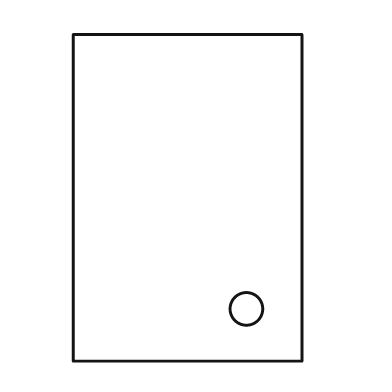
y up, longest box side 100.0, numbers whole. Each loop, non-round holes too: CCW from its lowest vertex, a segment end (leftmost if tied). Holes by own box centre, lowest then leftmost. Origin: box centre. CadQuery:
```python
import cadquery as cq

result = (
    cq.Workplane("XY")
    .moveTo(-35.0, -50.0)
    .lineTo(35.0, -50.0)
    .lineTo(35.0, 50.0)
    .lineTo(-35.0, 50.0)
    .close()
    .moveTo(18.0, -34.0)
    .circle(5.0)
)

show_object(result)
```